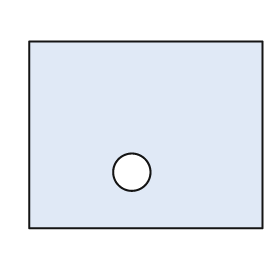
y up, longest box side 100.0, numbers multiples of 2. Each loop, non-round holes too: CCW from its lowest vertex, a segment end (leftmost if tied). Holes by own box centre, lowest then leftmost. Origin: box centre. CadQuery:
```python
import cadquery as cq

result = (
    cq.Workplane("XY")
    .moveTo(-50.0, -40.0)
    .lineTo(50.0, -40.0)
    .lineTo(50.0, 40.0)
    .lineTo(-50.0, 40.0)
    .close()
    .moveTo(-6.0, -16.0)
    .circle(8.0)
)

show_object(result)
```